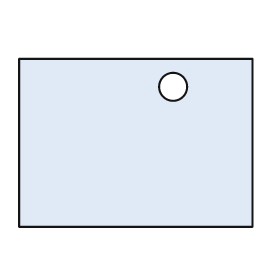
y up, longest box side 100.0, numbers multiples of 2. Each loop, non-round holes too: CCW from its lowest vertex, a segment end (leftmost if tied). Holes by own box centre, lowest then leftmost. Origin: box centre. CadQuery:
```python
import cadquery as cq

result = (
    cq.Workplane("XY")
    .moveTo(-50.0, -36.0)
    .lineTo(50.0, -36.0)
    .lineTo(50.0, 36.0)
    .lineTo(-50.0, 36.0)
    .close()
    .moveTo(16.0, 24.0)
    .circle(6.0)
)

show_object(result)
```